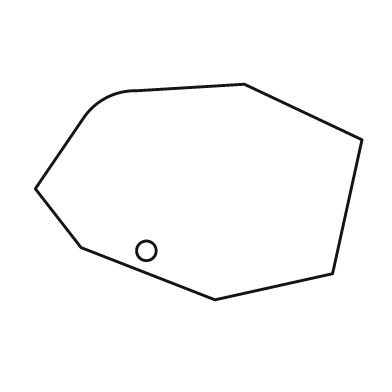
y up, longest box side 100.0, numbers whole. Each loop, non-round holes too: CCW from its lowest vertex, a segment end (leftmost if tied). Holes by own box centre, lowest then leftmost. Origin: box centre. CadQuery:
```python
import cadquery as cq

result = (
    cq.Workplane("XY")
    .moveTo(5.0, -33.0)
    .lineTo(41.0, -25.0)
    .lineTo(50.0, 16.0)
    .lineTo(14.0, 33.0)
    .lineTo(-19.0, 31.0)
    .threePointArc((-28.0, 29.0), (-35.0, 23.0))
    .lineTo(-50.0, 1.0)
    .lineTo(-36.0, -17.0)
    .close()
    .moveTo(-16.0, -18.0)
    .circle(3.0)
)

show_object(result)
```